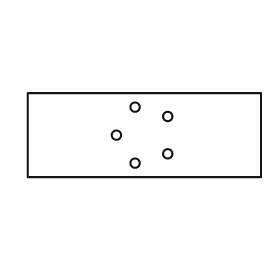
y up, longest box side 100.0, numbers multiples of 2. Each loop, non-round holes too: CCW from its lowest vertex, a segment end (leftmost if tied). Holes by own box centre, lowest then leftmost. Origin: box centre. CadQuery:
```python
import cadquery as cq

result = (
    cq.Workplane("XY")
    .moveTo(-50.0, -18.0)
    .lineTo(50.0, -18.0)
    .lineTo(50.0, 18.0)
    .lineTo(-50.0, 18.0)
    .close()
    .moveTo(-4.0, -12.0)
    .circle(2.0)
    .moveTo(10.0, -8.0)
    .circle(2.0)
    .moveTo(-12.0, 0.0)
    .circle(2.0)
    .moveTo(10.0, 8.0)
    .circle(2.0)
    .moveTo(-4.0, 12.0)
    .circle(2.0)
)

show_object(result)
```